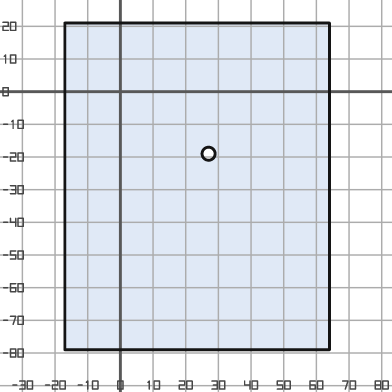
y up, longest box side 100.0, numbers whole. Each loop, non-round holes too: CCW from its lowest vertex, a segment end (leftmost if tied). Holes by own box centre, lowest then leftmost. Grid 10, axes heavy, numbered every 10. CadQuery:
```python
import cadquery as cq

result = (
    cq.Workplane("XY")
    .moveTo(-17.0, -79.0)
    .lineTo(64.0, -79.0)
    .lineTo(64.0, 21.0)
    .lineTo(-17.0, 21.0)
    .close()
    .moveTo(27.0, -19.0)
    .circle(2.0)
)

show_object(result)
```